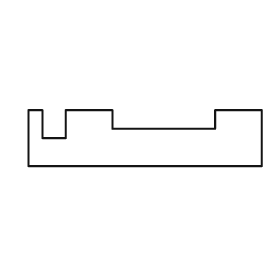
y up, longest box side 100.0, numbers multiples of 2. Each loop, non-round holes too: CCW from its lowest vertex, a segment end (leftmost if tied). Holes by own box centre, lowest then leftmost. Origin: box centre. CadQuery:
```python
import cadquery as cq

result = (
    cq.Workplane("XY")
    .moveTo(-50.0, -12.0)
    .lineTo(50.0, -12.0)
    .lineTo(50.0, 12.0)
    .lineTo(30.0, 12.0)
    .lineTo(30.0, 4.0)
    .lineTo(-14.0, 4.0)
    .lineTo(-14.0, 12.0)
    .lineTo(-34.0, 12.0)
    .lineTo(-34.0, 0.0)
    .lineTo(-44.0, 0.0)
    .lineTo(-44.0, 12.0)
    .lineTo(-50.0, 12.0)
    .close()
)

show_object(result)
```